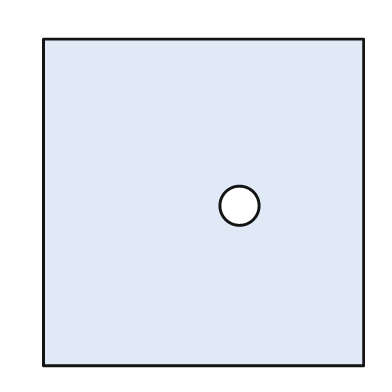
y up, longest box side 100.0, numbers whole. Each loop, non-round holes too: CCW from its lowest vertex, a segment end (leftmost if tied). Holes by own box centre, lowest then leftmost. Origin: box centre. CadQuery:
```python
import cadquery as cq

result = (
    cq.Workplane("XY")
    .moveTo(-49.0, -50.0)
    .lineTo(49.0, -50.0)
    .lineTo(49.0, 50.0)
    .lineTo(-49.0, 50.0)
    .close()
    .moveTo(11.0, -1.0)
    .circle(6.0)
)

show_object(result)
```